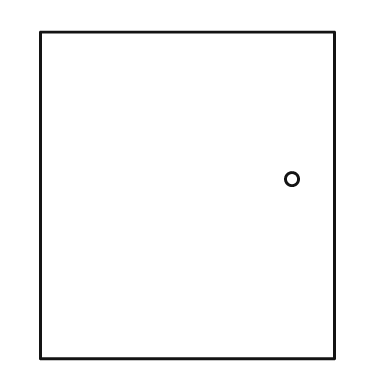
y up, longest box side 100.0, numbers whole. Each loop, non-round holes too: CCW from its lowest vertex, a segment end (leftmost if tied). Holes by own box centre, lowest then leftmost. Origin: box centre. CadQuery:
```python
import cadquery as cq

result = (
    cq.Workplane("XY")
    .moveTo(-45.0, -50.0)
    .lineTo(45.0, -50.0)
    .lineTo(45.0, 50.0)
    .lineTo(-45.0, 50.0)
    .close()
    .moveTo(32.0, 5.0)
    .circle(2.0)
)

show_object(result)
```